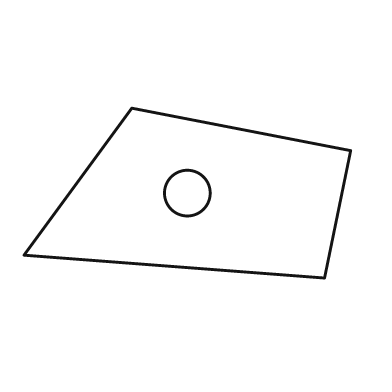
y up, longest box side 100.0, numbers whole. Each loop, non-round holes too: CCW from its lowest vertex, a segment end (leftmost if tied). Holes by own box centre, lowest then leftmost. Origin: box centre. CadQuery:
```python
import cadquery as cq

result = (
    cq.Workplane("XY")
    .moveTo(42.0, -26.0)
    .lineTo(50.0, 13.0)
    .lineTo(-17.0, 26.0)
    .lineTo(-50.0, -19.0)
    .close()
    .moveTo(0.0, 0.0)
    .circle(7.0)
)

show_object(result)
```